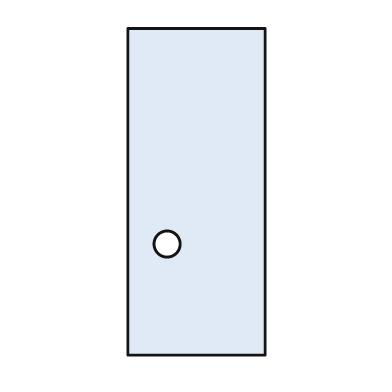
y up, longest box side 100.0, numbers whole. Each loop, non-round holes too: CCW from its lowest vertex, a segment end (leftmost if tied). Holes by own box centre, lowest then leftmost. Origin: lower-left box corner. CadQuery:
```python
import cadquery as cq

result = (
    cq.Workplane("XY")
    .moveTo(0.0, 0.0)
    .lineTo(42.0, 0.0)
    .lineTo(42.0, 100.0)
    .lineTo(0.0, 100.0)
    .close()
    .moveTo(12.0, 34.0)
    .circle(4.0)
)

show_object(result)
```